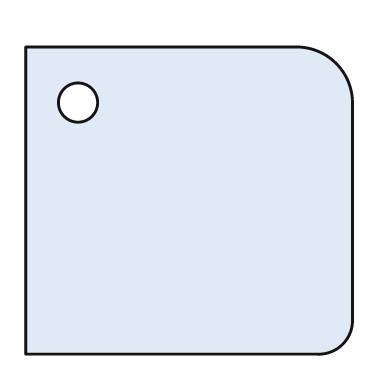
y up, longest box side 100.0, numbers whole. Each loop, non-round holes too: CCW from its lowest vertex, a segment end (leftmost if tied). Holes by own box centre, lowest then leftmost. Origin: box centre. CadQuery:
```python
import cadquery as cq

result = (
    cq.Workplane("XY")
    .moveTo(-50.0, -47.0)
    .lineTo(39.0, -47.0)
    .threePointArc((47.0, -44.0), (50.0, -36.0))
    .lineTo(50.0, 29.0)
    .threePointArc((45.0, 42.0), (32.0, 47.0))
    .lineTo(-50.0, 47.0)
    .close()
    .moveTo(-34.0, 30.0)
    .circle(6.0)
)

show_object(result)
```